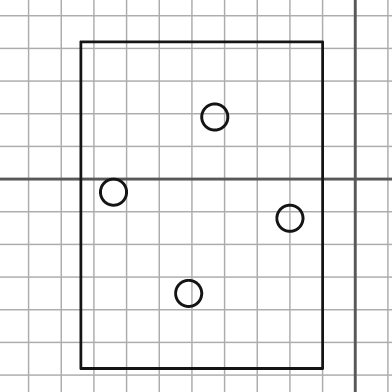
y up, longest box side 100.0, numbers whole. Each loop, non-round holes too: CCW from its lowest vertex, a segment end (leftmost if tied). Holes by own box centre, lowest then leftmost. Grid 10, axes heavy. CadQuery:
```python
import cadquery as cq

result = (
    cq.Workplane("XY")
    .moveTo(-84.0, -58.0)
    .lineTo(-10.0, -58.0)
    .lineTo(-10.0, 42.0)
    .lineTo(-84.0, 42.0)
    .close()
    .moveTo(-51.0, -35.0)
    .circle(4.0)
    .moveTo(-20.0, -12.0)
    .circle(4.0)
    .moveTo(-74.0, -4.0)
    .circle(4.0)
    .moveTo(-43.0, 19.0)
    .circle(4.0)
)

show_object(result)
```